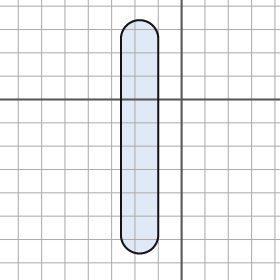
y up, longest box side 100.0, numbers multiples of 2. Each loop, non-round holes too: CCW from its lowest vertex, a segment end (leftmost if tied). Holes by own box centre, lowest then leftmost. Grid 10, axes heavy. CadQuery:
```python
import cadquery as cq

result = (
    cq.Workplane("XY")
    .moveTo(-26.0, -58.0)
    .threePointArc((-18.0, -66.0), (-10.0, -58.0))
    .lineTo(-10.0, 26.0)
    .threePointArc((-18.0, 34.0), (-26.0, 26.0))
    .close()
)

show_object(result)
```